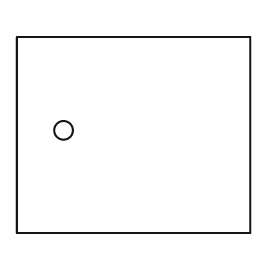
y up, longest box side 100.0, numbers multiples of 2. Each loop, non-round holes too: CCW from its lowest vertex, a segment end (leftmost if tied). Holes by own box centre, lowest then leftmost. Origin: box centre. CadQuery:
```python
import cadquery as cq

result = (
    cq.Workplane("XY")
    .moveTo(-50.0, -42.0)
    .lineTo(50.0, -42.0)
    .lineTo(50.0, 42.0)
    .lineTo(-50.0, 42.0)
    .close()
    .moveTo(-30.0, 2.0)
    .circle(4.0)
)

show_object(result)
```